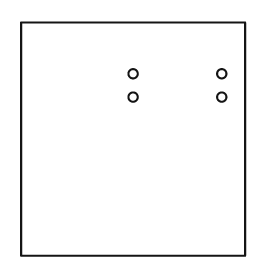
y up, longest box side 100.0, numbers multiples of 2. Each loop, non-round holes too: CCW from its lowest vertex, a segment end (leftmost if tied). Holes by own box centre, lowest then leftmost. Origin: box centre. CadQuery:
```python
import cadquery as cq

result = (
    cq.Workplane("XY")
    .moveTo(-48.0, -50.0)
    .lineTo(48.0, -50.0)
    .lineTo(48.0, 50.0)
    .lineTo(-48.0, 50.0)
    .close()
    .moveTo(0.0, 18.0)
    .circle(2.0)
    .moveTo(38.0, 18.0)
    .circle(2.0)
    .moveTo(0.0, 28.0)
    .circle(2.0)
    .moveTo(38.0, 28.0)
    .circle(2.0)
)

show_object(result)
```